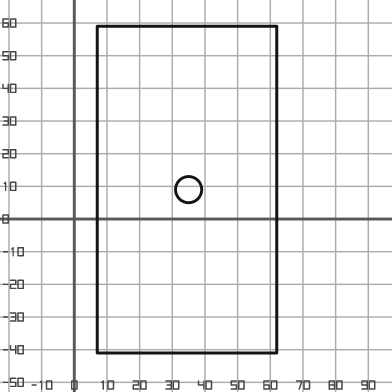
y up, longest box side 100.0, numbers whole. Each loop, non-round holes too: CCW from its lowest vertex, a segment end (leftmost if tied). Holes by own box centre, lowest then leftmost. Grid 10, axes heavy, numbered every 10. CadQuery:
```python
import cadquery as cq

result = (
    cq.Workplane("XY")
    .moveTo(7.0, -41.0)
    .lineTo(62.0, -41.0)
    .lineTo(62.0, 59.0)
    .lineTo(7.0, 59.0)
    .close()
    .moveTo(35.0, 9.0)
    .circle(4.0)
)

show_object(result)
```